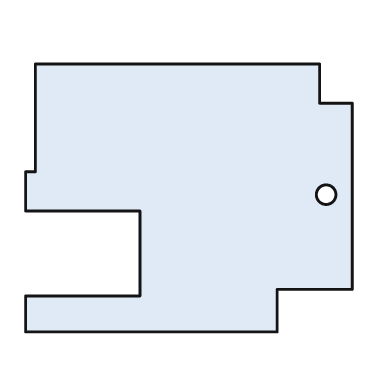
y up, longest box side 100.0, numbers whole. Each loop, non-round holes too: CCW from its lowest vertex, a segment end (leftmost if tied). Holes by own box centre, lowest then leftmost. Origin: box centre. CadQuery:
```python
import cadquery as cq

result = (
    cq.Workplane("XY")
    .moveTo(-50.0, -41.0)
    .lineTo(27.0, -41.0)
    .lineTo(27.0, -28.0)
    .lineTo(50.0, -28.0)
    .lineTo(50.0, 29.0)
    .lineTo(40.0, 29.0)
    .lineTo(40.0, 41.0)
    .lineTo(-47.0, 41.0)
    .lineTo(-47.0, 8.0)
    .lineTo(-50.0, 8.0)
    .lineTo(-50.0, -4.0)
    .lineTo(-15.0, -4.0)
    .lineTo(-15.0, -30.0)
    .lineTo(-50.0, -30.0)
    .close()
    .moveTo(42.0, 1.0)
    .circle(3.0)
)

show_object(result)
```